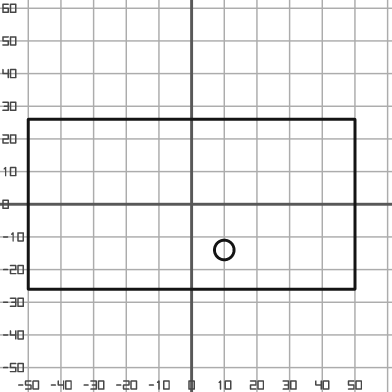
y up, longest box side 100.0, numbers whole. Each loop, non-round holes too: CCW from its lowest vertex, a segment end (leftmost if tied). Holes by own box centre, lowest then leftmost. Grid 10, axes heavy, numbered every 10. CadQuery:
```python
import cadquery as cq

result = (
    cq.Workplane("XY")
    .moveTo(-50.0, -26.0)
    .lineTo(50.0, -26.0)
    .lineTo(50.0, 26.0)
    .lineTo(-50.0, 26.0)
    .close()
    .moveTo(10.0, -14.0)
    .circle(3.0)
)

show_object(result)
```